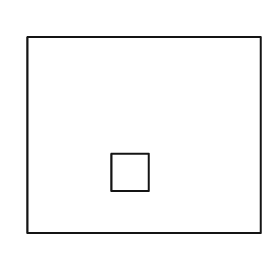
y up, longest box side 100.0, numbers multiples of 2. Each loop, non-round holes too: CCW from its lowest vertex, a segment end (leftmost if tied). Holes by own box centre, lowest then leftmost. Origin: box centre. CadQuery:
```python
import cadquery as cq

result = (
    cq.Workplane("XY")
    .moveTo(-50.0, -42.0)
    .lineTo(50.0, -42.0)
    .lineTo(50.0, 42.0)
    .lineTo(-50.0, 42.0)
    .close()
    .moveTo(-14.0, -24.0)
    .lineTo(2.0, -24.0)
    .lineTo(2.0, -8.0)
    .lineTo(-14.0, -8.0)
    .close()
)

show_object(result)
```